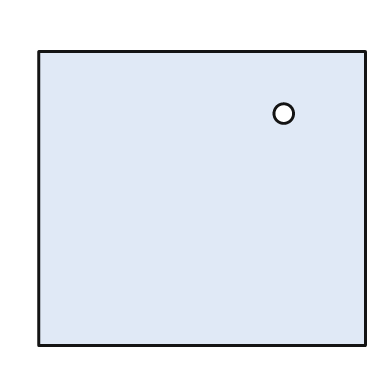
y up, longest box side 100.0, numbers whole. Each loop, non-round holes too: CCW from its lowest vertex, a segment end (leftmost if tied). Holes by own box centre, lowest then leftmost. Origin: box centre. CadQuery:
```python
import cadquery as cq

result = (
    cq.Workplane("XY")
    .moveTo(-50.0, -45.0)
    .lineTo(50.0, -45.0)
    .lineTo(50.0, 45.0)
    .lineTo(-50.0, 45.0)
    .close()
    .moveTo(25.0, 26.0)
    .circle(3.0)
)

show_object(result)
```